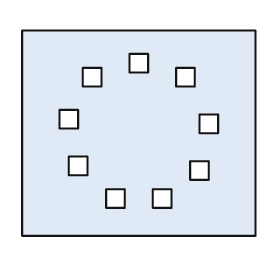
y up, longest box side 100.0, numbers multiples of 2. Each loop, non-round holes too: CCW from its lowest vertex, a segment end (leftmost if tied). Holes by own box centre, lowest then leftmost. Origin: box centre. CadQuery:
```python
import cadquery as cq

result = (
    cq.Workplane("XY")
    .moveTo(-50.0, -44.0)
    .lineTo(50.0, -44.0)
    .lineTo(50.0, 44.0)
    .lineTo(-50.0, 44.0)
    .close()
    .moveTo(-14.0, -32.0)
    .lineTo(-6.0, -32.0)
    .lineTo(-6.0, -24.0)
    .lineTo(-14.0, -24.0)
    .close()
    .moveTo(6.0, -32.0)
    .lineTo(14.0, -32.0)
    .lineTo(14.0, -24.0)
    .lineTo(6.0, -24.0)
    .close()
    .moveTo(22.0, -20.0)
    .lineTo(30.0, -20.0)
    .lineTo(30.0, -12.0)
    .lineTo(22.0, -12.0)
    .close()
    .moveTo(-30.0, -18.0)
    .lineTo(-22.0, -18.0)
    .lineTo(-22.0, -10.0)
    .lineTo(-30.0, -10.0)
    .close()
    .moveTo(26.0, 0.0)
    .lineTo(34.0, 0.0)
    .lineTo(34.0, 8.0)
    .lineTo(26.0, 8.0)
    .close()
    .moveTo(-34.0, 2.0)
    .lineTo(-26.0, 2.0)
    .lineTo(-26.0, 10.0)
    .lineTo(-34.0, 10.0)
    .close()
    .moveTo(-24.0, 20.0)
    .lineTo(-16.0, 20.0)
    .lineTo(-16.0, 28.0)
    .lineTo(-24.0, 28.0)
    .close()
    .moveTo(16.0, 20.0)
    .lineTo(24.0, 20.0)
    .lineTo(24.0, 28.0)
    .lineTo(16.0, 28.0)
    .close()
    .moveTo(-4.0, 26.0)
    .lineTo(4.0, 26.0)
    .lineTo(4.0, 34.0)
    .lineTo(-4.0, 34.0)
    .close()
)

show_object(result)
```